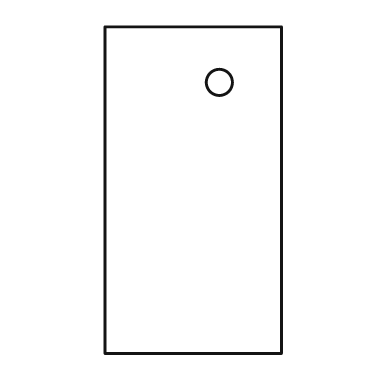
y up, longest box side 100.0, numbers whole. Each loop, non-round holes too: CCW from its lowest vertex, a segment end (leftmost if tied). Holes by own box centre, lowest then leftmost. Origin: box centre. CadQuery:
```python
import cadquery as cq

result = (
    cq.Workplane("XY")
    .moveTo(-27.0, -50.0)
    .lineTo(27.0, -50.0)
    .lineTo(27.0, 50.0)
    .lineTo(-27.0, 50.0)
    .close()
    .moveTo(8.0, 33.0)
    .circle(4.0)
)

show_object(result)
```